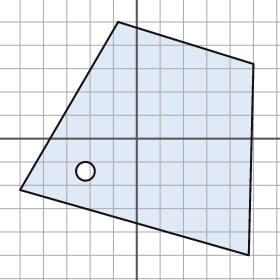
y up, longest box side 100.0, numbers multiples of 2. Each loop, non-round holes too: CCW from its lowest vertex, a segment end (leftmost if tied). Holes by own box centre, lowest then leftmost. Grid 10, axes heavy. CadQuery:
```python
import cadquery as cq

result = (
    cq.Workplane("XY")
    .moveTo(48.0, -50.0)
    .lineTo(50.0, 32.0)
    .lineTo(-8.0, 50.0)
    .lineTo(-50.0, -22.0)
    .close()
    .moveTo(-22.0, -14.0)
    .circle(4.0)
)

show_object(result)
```